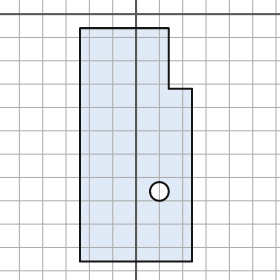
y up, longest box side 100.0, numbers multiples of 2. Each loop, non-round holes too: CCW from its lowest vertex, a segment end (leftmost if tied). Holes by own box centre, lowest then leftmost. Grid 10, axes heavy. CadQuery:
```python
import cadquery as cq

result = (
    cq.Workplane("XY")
    .moveTo(-24.0, -106.0)
    .lineTo(24.0, -106.0)
    .lineTo(24.0, -32.0)
    .lineTo(14.0, -32.0)
    .lineTo(14.0, -6.0)
    .lineTo(-24.0, -6.0)
    .close()
    .moveTo(10.0, -76.0)
    .circle(4.0)
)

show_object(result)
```